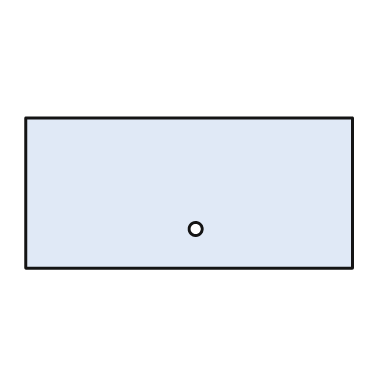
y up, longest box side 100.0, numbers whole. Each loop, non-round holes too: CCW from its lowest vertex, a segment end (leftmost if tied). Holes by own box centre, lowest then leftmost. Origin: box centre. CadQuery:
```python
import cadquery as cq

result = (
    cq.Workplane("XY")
    .moveTo(-50.0, -23.0)
    .lineTo(50.0, -23.0)
    .lineTo(50.0, 23.0)
    .lineTo(-50.0, 23.0)
    .close()
    .moveTo(2.0, -11.0)
    .circle(2.0)
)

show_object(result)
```